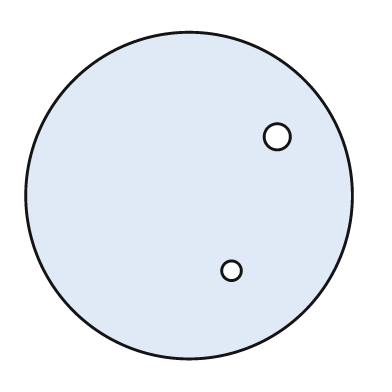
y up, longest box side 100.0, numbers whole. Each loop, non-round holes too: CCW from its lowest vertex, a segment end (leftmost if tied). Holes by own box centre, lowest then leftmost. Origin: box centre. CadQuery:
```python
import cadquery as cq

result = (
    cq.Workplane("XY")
    .moveTo(0.0, 0.0)
    .circle(50.0)
    .moveTo(13.0, -23.0)
    .circle(3.0)
    .moveTo(27.0, 18.0)
    .circle(4.0)
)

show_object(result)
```